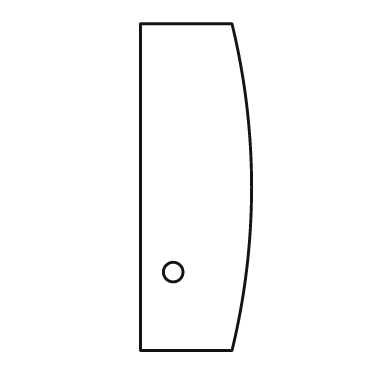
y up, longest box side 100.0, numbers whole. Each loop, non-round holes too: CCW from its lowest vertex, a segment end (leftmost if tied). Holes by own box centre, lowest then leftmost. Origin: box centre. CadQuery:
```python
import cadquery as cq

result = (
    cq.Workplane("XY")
    .moveTo(-17.0, -50.0)
    .lineTo(11.0, -50.0)
    .threePointArc((17.0, 0.0), (11.0, 50.0))
    .lineTo(-17.0, 50.0)
    .close()
    .moveTo(-7.0, -26.0)
    .circle(3.0)
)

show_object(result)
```